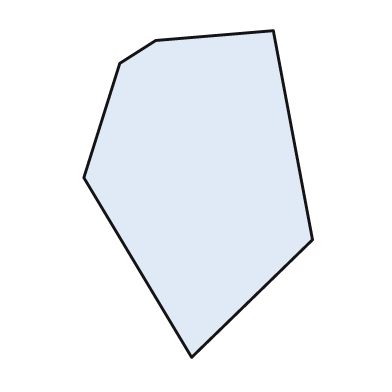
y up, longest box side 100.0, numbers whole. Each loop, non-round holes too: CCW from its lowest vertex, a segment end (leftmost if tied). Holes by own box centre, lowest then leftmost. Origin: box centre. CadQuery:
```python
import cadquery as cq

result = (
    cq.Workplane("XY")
    .moveTo(-2.0, -50.0)
    .lineTo(35.0, -14.0)
    .lineTo(23.0, 50.0)
    .lineTo(-13.0, 47.0)
    .lineTo(-24.0, 40.0)
    .lineTo(-35.0, 5.0)
    .close()
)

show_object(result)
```